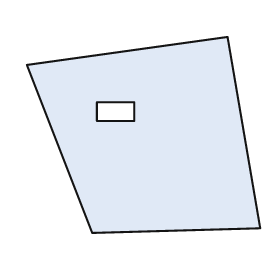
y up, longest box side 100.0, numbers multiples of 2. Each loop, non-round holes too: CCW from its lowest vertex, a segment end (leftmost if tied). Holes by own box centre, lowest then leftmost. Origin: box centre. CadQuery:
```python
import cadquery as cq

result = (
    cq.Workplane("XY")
    .moveTo(-22.0, -42.0)
    .lineTo(50.0, -40.0)
    .lineTo(36.0, 42.0)
    .lineTo(-50.0, 30.0)
    .close()
    .moveTo(-20.0, 6.0)
    .lineTo(-4.0, 6.0)
    .lineTo(-4.0, 14.0)
    .lineTo(-20.0, 14.0)
    .close()
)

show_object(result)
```